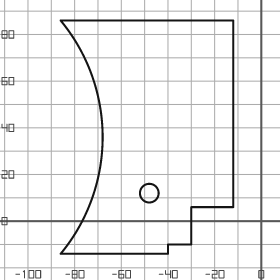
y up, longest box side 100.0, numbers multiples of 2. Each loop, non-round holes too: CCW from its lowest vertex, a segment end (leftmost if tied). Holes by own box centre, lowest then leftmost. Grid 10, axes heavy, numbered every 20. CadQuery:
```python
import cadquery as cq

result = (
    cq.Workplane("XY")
    .moveTo(-86.0, -14.0)
    .lineTo(-40.0, -14.0)
    .lineTo(-40.0, -10.0)
    .lineTo(-30.0, -10.0)
    .lineTo(-30.0, 6.0)
    .lineTo(-12.0, 6.0)
    .lineTo(-12.0, 86.0)
    .lineTo(-86.0, 86.0)
    .threePointArc((-68.0, 36.0), (-86.0, -14.0))
    .close()
    .moveTo(-48.0, 12.0)
    .circle(4.0)
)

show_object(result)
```